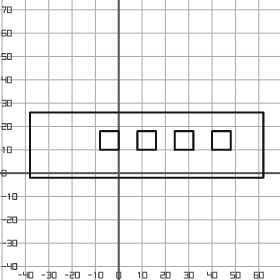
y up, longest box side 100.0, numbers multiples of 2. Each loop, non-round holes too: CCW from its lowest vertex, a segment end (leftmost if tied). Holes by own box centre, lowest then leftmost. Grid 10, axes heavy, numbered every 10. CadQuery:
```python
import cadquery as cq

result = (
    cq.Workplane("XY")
    .moveTo(-38.0, -2.0)
    .lineTo(62.0, -2.0)
    .lineTo(62.0, 26.0)
    .lineTo(-38.0, 26.0)
    .close()
    .moveTo(-8.0, 10.0)
    .lineTo(0.0, 10.0)
    .lineTo(0.0, 18.0)
    .lineTo(-8.0, 18.0)
    .close()
    .moveTo(8.0, 10.0)
    .lineTo(16.0, 10.0)
    .lineTo(16.0, 18.0)
    .lineTo(8.0, 18.0)
    .close()
    .moveTo(24.0, 10.0)
    .lineTo(32.0, 10.0)
    .lineTo(32.0, 18.0)
    .lineTo(24.0, 18.0)
    .close()
    .moveTo(40.0, 10.0)
    .lineTo(48.0, 10.0)
    .lineTo(48.0, 18.0)
    .lineTo(40.0, 18.0)
    .close()
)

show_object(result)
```